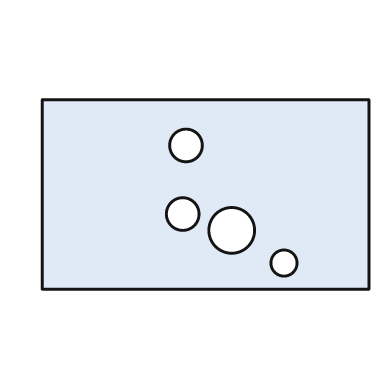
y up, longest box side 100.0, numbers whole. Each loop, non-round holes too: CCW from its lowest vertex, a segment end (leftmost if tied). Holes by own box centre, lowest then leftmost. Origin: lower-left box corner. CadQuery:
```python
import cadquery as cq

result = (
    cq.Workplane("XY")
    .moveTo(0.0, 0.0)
    .lineTo(100.0, 0.0)
    .lineTo(100.0, 58.0)
    .lineTo(0.0, 58.0)
    .close()
    .moveTo(74.0, 8.0)
    .circle(4.0)
    .moveTo(58.0, 18.0)
    .circle(7.0)
    .moveTo(43.0, 23.0)
    .circle(5.0)
    .moveTo(44.0, 44.0)
    .circle(5.0)
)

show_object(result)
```